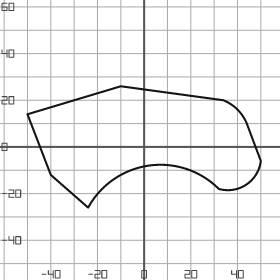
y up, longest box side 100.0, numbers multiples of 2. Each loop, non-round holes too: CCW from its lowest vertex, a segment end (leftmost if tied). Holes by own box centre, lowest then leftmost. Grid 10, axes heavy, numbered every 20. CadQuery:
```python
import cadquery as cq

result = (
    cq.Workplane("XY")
    .moveTo(-24.0, -26.0)
    .threePointArc((2.0, -8.0), (32.0, -18.0))
    .threePointArc((44.0, -16.0), (50.0, -6.0))
    .lineTo(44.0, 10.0)
    .threePointArc((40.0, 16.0), (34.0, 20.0))
    .lineTo(-10.0, 26.0)
    .lineTo(-50.0, 14.0)
    .lineTo(-40.0, -12.0)
    .close()
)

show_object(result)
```